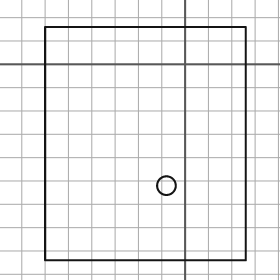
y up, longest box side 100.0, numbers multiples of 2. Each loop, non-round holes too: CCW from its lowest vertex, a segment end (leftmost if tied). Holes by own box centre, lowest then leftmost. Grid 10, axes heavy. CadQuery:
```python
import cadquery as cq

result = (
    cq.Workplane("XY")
    .moveTo(-60.0, -84.0)
    .lineTo(26.0, -84.0)
    .lineTo(26.0, 16.0)
    .lineTo(-60.0, 16.0)
    .close()
    .moveTo(-8.0, -52.0)
    .circle(4.0)
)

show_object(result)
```